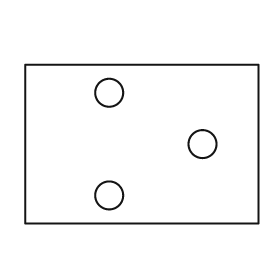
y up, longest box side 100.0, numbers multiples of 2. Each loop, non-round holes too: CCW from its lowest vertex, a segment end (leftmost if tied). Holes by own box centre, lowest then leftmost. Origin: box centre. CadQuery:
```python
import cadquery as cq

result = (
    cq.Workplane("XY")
    .moveTo(-50.0, -34.0)
    .lineTo(50.0, -34.0)
    .lineTo(50.0, 34.0)
    .lineTo(-50.0, 34.0)
    .close()
    .moveTo(-14.0, -22.0)
    .circle(6.0)
    .moveTo(26.0, 0.0)
    .circle(6.0)
    .moveTo(-14.0, 22.0)
    .circle(6.0)
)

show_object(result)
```